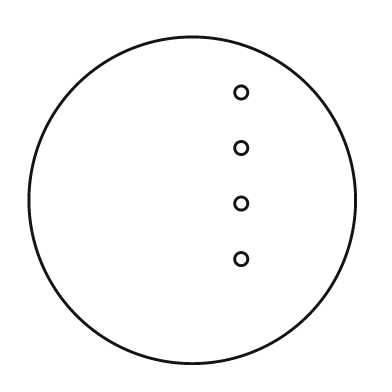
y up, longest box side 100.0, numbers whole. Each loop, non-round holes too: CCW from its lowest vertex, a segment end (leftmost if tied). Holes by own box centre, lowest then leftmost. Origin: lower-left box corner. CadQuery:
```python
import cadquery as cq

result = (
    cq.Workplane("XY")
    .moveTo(50.0, 50.0)
    .circle(50.0)
    .moveTo(65.0, 32.0)
    .circle(2.0)
    .moveTo(65.0, 49.0)
    .circle(2.0)
    .moveTo(65.0, 66.0)
    .circle(2.0)
    .moveTo(65.0, 83.0)
    .circle(2.0)
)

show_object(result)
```